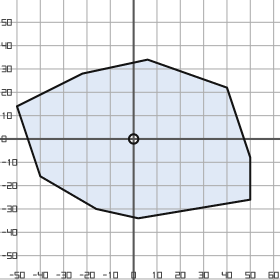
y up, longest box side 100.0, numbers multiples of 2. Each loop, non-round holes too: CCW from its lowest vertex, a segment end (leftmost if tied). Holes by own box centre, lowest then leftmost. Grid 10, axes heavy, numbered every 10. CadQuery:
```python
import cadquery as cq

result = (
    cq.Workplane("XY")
    .moveTo(2.0, -34.0)
    .lineTo(50.0, -26.0)
    .lineTo(50.0, -8.0)
    .lineTo(40.0, 22.0)
    .lineTo(6.0, 34.0)
    .lineTo(-22.0, 28.0)
    .lineTo(-50.0, 14.0)
    .lineTo(-40.0, -16.0)
    .lineTo(-16.0, -30.0)
    .close()
    .moveTo(0.0, 0.0)
    .circle(2.0)
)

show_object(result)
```